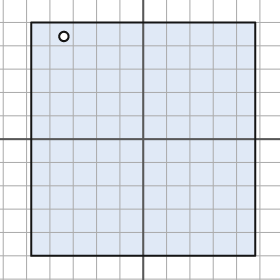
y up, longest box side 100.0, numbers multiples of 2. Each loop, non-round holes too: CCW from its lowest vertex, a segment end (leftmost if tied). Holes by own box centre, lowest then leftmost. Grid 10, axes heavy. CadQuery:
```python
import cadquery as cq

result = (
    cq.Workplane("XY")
    .moveTo(-48.0, -50.0)
    .lineTo(48.0, -50.0)
    .lineTo(48.0, 50.0)
    .lineTo(-48.0, 50.0)
    .close()
    .moveTo(-34.0, 44.0)
    .circle(2.0)
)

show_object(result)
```